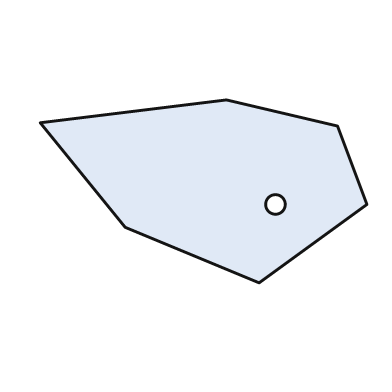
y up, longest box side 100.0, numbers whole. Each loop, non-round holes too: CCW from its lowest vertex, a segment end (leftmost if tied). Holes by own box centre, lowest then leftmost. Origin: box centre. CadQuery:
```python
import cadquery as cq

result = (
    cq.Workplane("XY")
    .moveTo(17.0, -28.0)
    .lineTo(50.0, -4.0)
    .lineTo(41.0, 20.0)
    .lineTo(7.0, 28.0)
    .lineTo(-50.0, 21.0)
    .lineTo(-24.0, -11.0)
    .close()
    .moveTo(22.0, -4.0)
    .circle(3.0)
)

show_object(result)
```